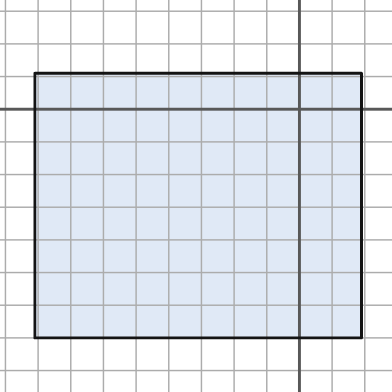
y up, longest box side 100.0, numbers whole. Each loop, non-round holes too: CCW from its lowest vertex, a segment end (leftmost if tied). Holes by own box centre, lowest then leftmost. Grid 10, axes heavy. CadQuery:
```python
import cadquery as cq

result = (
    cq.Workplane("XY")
    .moveTo(-81.0, -70.0)
    .lineTo(19.0, -70.0)
    .lineTo(19.0, 11.0)
    .lineTo(-81.0, 11.0)
    .close()
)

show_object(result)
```